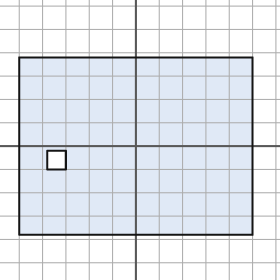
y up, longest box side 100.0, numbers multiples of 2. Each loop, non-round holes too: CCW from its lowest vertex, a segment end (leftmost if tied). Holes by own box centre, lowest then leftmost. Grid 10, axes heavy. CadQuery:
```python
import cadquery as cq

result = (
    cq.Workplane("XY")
    .moveTo(-50.0, -38.0)
    .lineTo(50.0, -38.0)
    .lineTo(50.0, 38.0)
    .lineTo(-50.0, 38.0)
    .close()
    .moveTo(-38.0, -10.0)
    .lineTo(-30.0, -10.0)
    .lineTo(-30.0, -2.0)
    .lineTo(-38.0, -2.0)
    .close()
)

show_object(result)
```